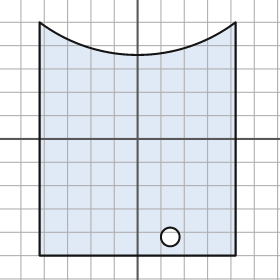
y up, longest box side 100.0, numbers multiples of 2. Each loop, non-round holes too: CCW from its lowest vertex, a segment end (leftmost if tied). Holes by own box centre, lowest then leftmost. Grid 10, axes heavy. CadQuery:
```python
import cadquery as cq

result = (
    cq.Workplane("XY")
    .moveTo(-42.0, -50.0)
    .lineTo(42.0, -50.0)
    .lineTo(42.0, 50.0)
    .threePointArc((0.0, 36.0), (-42.0, 50.0))
    .close()
    .moveTo(14.0, -42.0)
    .circle(4.0)
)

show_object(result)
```